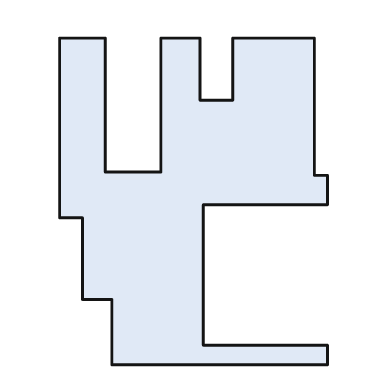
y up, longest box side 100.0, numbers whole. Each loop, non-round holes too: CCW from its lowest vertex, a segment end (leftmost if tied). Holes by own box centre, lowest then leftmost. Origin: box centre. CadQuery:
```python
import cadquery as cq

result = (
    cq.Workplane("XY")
    .moveTo(-25.0, -50.0)
    .lineTo(41.0, -50.0)
    .lineTo(41.0, -44.0)
    .lineTo(3.0, -44.0)
    .lineTo(3.0, -1.0)
    .lineTo(41.0, -1.0)
    .lineTo(41.0, 8.0)
    .lineTo(37.0, 8.0)
    .lineTo(37.0, 50.0)
    .lineTo(12.0, 50.0)
    .lineTo(12.0, 31.0)
    .lineTo(2.0, 31.0)
    .lineTo(2.0, 50.0)
    .lineTo(-10.0, 50.0)
    .lineTo(-10.0, 9.0)
    .lineTo(-27.0, 9.0)
    .lineTo(-27.0, 50.0)
    .lineTo(-41.0, 50.0)
    .lineTo(-41.0, -5.0)
    .lineTo(-34.0, -5.0)
    .lineTo(-34.0, -30.0)
    .lineTo(-25.0, -30.0)
    .close()
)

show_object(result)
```